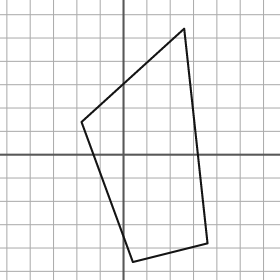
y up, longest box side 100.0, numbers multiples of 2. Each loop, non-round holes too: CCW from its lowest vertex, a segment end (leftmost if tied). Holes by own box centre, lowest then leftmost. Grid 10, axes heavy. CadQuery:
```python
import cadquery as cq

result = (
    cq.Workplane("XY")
    .moveTo(4.0, -46.0)
    .lineTo(36.0, -38.0)
    .lineTo(26.0, 54.0)
    .lineTo(-18.0, 14.0)
    .close()
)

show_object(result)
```